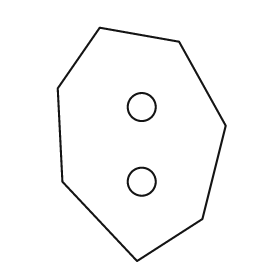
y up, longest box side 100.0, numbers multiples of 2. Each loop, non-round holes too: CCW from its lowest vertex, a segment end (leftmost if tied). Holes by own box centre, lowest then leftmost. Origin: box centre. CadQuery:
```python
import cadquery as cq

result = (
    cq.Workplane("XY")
    .moveTo(-2.0, -50.0)
    .lineTo(26.0, -32.0)
    .lineTo(36.0, 8.0)
    .lineTo(16.0, 44.0)
    .lineTo(-18.0, 50.0)
    .lineTo(-36.0, 24.0)
    .lineTo(-34.0, -16.0)
    .close()
    .moveTo(0.0, -16.0)
    .circle(6.0)
    .moveTo(0.0, 16.0)
    .circle(6.0)
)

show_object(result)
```